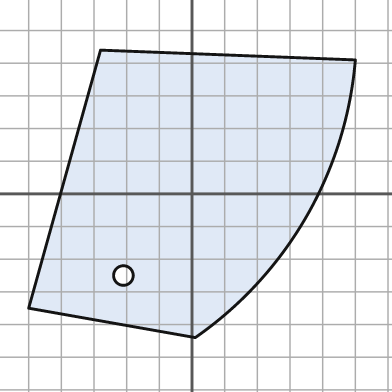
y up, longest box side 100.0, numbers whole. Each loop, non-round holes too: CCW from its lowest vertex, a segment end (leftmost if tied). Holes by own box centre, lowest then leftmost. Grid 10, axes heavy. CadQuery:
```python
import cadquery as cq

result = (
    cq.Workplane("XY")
    .moveTo(1.0, -44.0)
    .threePointArc((35.0, -7.0), (50.0, 41.0))
    .lineTo(-28.0, 44.0)
    .lineTo(-50.0, -35.0)
    .close()
    .moveTo(-21.0, -25.0)
    .circle(3.0)
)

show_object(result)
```